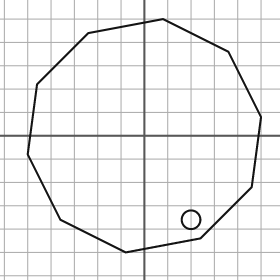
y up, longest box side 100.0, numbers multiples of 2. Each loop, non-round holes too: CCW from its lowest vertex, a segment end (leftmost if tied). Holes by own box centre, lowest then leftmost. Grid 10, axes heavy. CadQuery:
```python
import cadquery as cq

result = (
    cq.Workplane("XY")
    .moveTo(-8.0, -50.0)
    .lineTo(24.0, -44.0)
    .lineTo(46.0, -22.0)
    .lineTo(50.0, 8.0)
    .lineTo(36.0, 36.0)
    .lineTo(8.0, 50.0)
    .lineTo(-24.0, 44.0)
    .lineTo(-46.0, 22.0)
    .lineTo(-50.0, -8.0)
    .lineTo(-36.0, -36.0)
    .close()
    .moveTo(20.0, -36.0)
    .circle(4.0)
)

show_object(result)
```